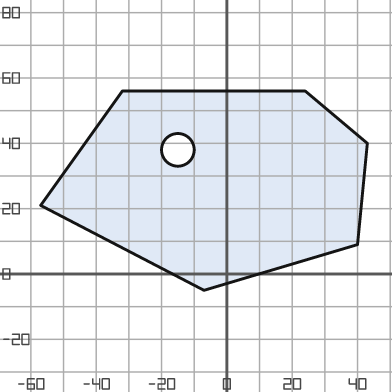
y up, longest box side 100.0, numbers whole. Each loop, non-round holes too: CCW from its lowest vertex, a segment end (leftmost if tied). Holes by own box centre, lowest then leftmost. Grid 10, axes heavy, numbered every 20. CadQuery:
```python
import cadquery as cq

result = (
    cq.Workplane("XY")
    .moveTo(-7.0, -5.0)
    .lineTo(40.0, 9.0)
    .lineTo(43.0, 40.0)
    .lineTo(24.0, 56.0)
    .lineTo(-32.0, 56.0)
    .lineTo(-57.0, 21.0)
    .close()
    .moveTo(-15.0, 38.0)
    .circle(5.0)
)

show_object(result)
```